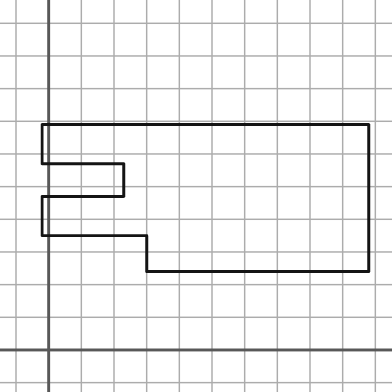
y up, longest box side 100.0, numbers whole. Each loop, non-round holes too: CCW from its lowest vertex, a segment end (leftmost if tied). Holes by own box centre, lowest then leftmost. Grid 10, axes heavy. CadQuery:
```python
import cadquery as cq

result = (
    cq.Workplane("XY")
    .moveTo(30.0, 24.0)
    .lineTo(98.0, 24.0)
    .lineTo(98.0, 69.0)
    .lineTo(-2.0, 69.0)
    .lineTo(-2.0, 57.0)
    .lineTo(23.0, 57.0)
    .lineTo(23.0, 47.0)
    .lineTo(-2.0, 47.0)
    .lineTo(-2.0, 35.0)
    .lineTo(30.0, 35.0)
    .close()
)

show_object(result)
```